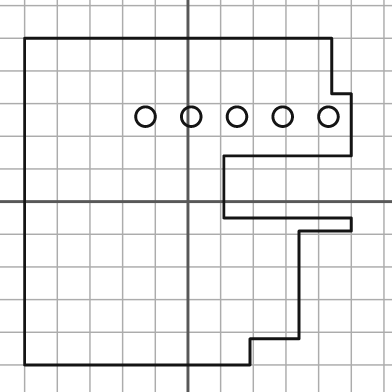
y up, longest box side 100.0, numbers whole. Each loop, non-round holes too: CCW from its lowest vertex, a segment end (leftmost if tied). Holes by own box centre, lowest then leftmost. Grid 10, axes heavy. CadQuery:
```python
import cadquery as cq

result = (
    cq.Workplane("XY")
    .moveTo(-50.0, -50.0)
    .lineTo(19.0, -50.0)
    .lineTo(19.0, -42.0)
    .lineTo(34.0, -42.0)
    .lineTo(34.0, -9.0)
    .lineTo(50.0, -9.0)
    .lineTo(50.0, -5.0)
    .lineTo(11.0, -5.0)
    .lineTo(11.0, 14.0)
    .lineTo(50.0, 14.0)
    .lineTo(50.0, 33.0)
    .lineTo(44.0, 33.0)
    .lineTo(44.0, 50.0)
    .lineTo(-50.0, 50.0)
    .close()
    .moveTo(-13.0, 26.0)
    .circle(3.0)
    .moveTo(1.0, 26.0)
    .circle(3.0)
    .moveTo(15.0, 26.0)
    .circle(3.0)
    .moveTo(29.0, 26.0)
    .circle(3.0)
    .moveTo(43.0, 26.0)
    .circle(3.0)
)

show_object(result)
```